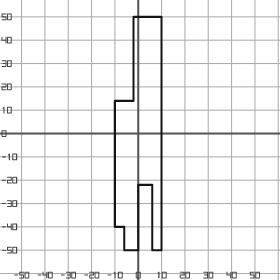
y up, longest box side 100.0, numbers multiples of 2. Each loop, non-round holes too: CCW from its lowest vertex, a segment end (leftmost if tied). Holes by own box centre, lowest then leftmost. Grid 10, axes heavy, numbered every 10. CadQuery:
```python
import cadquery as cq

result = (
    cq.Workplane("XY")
    .moveTo(-6.0, -50.0)
    .lineTo(0.0, -50.0)
    .lineTo(0.0, -22.0)
    .lineTo(6.0, -22.0)
    .lineTo(6.0, -50.0)
    .lineTo(10.0, -50.0)
    .lineTo(10.0, 50.0)
    .lineTo(-2.0, 50.0)
    .lineTo(-2.0, 14.0)
    .lineTo(-10.0, 14.0)
    .lineTo(-10.0, -40.0)
    .lineTo(-6.0, -40.0)
    .close()
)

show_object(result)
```